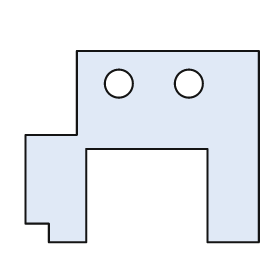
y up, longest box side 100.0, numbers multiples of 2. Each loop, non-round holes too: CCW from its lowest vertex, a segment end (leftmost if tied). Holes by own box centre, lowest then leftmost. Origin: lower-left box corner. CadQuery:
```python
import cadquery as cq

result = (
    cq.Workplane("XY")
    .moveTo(10.0, 0.0)
    .lineTo(26.0, 0.0)
    .lineTo(26.0, 40.0)
    .lineTo(78.0, 40.0)
    .lineTo(78.0, 0.0)
    .lineTo(100.0, 0.0)
    .lineTo(100.0, 82.0)
    .lineTo(22.0, 82.0)
    .lineTo(22.0, 46.0)
    .lineTo(0.0, 46.0)
    .lineTo(0.0, 8.0)
    .lineTo(10.0, 8.0)
    .close()
    .moveTo(40.0, 68.0)
    .circle(6.0)
    .moveTo(70.0, 68.0)
    .circle(6.0)
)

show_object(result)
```